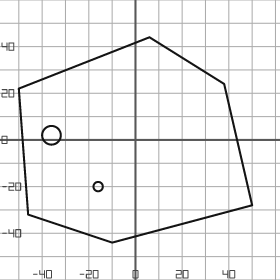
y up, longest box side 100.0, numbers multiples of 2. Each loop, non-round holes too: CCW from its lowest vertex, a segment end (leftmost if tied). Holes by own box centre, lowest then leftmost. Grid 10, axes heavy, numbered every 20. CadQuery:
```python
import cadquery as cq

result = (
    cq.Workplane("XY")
    .moveTo(-10.0, -44.0)
    .lineTo(50.0, -28.0)
    .lineTo(38.0, 24.0)
    .lineTo(6.0, 44.0)
    .lineTo(-50.0, 22.0)
    .lineTo(-46.0, -32.0)
    .close()
    .moveTo(-16.0, -20.0)
    .circle(2.0)
    .moveTo(-36.0, 2.0)
    .circle(4.0)
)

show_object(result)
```